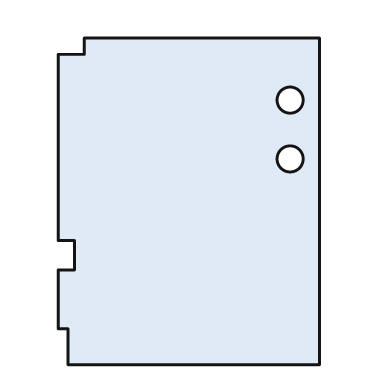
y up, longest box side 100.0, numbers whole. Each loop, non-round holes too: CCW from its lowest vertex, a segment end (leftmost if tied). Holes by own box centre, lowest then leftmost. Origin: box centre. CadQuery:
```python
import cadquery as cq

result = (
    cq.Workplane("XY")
    .moveTo(-37.0, -50.0)
    .lineTo(40.0, -50.0)
    .lineTo(40.0, 50.0)
    .lineTo(-32.0, 50.0)
    .lineTo(-32.0, 45.0)
    .lineTo(-40.0, 45.0)
    .lineTo(-40.0, -12.0)
    .lineTo(-35.0, -12.0)
    .lineTo(-35.0, -21.0)
    .lineTo(-40.0, -21.0)
    .lineTo(-40.0, -39.0)
    .lineTo(-37.0, -39.0)
    .close()
    .moveTo(31.0, 13.0)
    .circle(4.0)
    .moveTo(31.0, 31.0)
    .circle(4.0)
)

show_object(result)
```